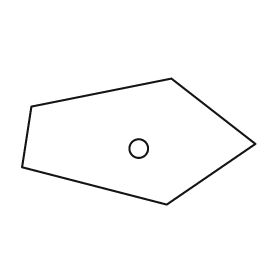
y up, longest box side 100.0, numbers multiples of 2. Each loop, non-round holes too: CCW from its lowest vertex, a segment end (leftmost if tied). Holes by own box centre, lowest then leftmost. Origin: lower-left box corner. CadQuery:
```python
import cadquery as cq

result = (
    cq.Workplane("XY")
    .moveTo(62.0, 0.0)
    .lineTo(100.0, 26.0)
    .lineTo(64.0, 54.0)
    .lineTo(4.0, 42.0)
    .lineTo(0.0, 16.0)
    .close()
    .moveTo(50.0, 24.0)
    .circle(4.0)
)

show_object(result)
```